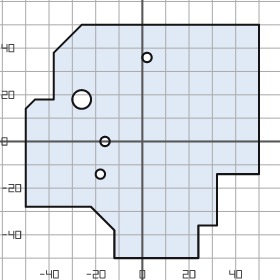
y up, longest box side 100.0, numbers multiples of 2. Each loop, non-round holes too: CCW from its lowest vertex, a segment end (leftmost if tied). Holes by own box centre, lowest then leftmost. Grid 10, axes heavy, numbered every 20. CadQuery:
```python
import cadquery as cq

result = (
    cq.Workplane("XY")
    .moveTo(-12.0, -50.0)
    .lineTo(24.0, -50.0)
    .lineTo(24.0, -36.0)
    .lineTo(32.0, -36.0)
    .lineTo(32.0, -14.0)
    .lineTo(50.0, -14.0)
    .lineTo(50.0, 50.0)
    .lineTo(-26.0, 50.0)
    .lineTo(-38.0, 38.0)
    .lineTo(-38.0, 18.0)
    .lineTo(-46.0, 18.0)
    .lineTo(-50.0, 14.0)
    .lineTo(-50.0, -28.0)
    .lineTo(-22.0, -28.0)
    .lineTo(-12.0, -38.0)
    .close()
    .moveTo(-18.0, -14.0)
    .circle(2.0)
    .moveTo(-16.0, 0.0)
    .circle(2.0)
    .moveTo(-26.0, 18.0)
    .circle(4.0)
    .moveTo(2.0, 36.0)
    .circle(2.0)
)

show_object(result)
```